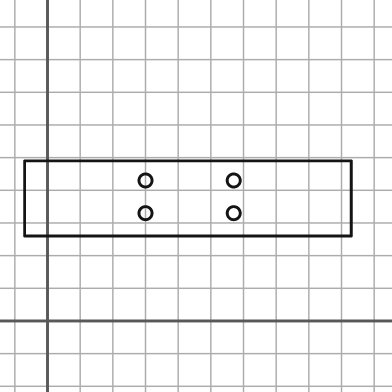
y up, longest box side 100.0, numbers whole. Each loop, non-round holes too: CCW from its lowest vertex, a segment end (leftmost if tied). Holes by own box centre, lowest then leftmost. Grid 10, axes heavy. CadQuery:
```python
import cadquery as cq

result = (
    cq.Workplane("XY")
    .moveTo(-7.0, 26.0)
    .lineTo(93.0, 26.0)
    .lineTo(93.0, 49.0)
    .lineTo(-7.0, 49.0)
    .close()
    .moveTo(30.0, 33.0)
    .circle(2.0)
    .moveTo(57.0, 33.0)
    .circle(2.0)
    .moveTo(30.0, 43.0)
    .circle(2.0)
    .moveTo(57.0, 43.0)
    .circle(2.0)
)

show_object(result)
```